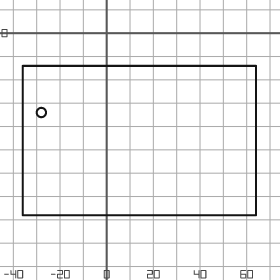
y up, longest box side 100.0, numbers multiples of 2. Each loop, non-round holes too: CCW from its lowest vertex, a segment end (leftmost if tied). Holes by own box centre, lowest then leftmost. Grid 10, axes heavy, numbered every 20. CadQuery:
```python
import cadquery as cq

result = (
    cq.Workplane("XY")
    .moveTo(-36.0, -78.0)
    .lineTo(64.0, -78.0)
    .lineTo(64.0, -14.0)
    .lineTo(-36.0, -14.0)
    .close()
    .moveTo(-28.0, -34.0)
    .circle(2.0)
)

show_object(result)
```